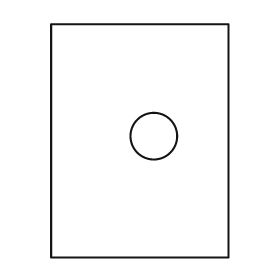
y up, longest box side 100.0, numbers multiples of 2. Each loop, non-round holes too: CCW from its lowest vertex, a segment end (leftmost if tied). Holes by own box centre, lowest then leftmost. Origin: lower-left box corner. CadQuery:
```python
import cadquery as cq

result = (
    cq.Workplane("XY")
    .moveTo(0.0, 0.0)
    .lineTo(76.0, 0.0)
    .lineTo(76.0, 100.0)
    .lineTo(0.0, 100.0)
    .close()
    .moveTo(44.0, 52.0)
    .circle(10.0)
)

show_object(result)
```